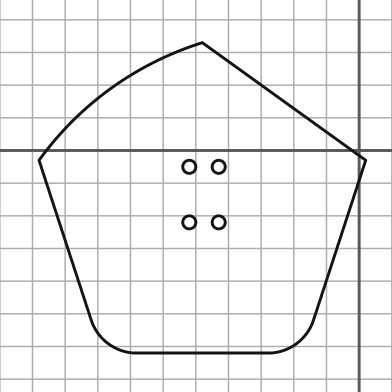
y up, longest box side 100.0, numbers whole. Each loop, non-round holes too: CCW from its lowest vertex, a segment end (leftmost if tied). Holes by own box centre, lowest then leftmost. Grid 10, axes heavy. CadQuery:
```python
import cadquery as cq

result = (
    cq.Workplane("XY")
    .moveTo(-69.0, -62.0)
    .lineTo(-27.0, -62.0)
    .threePointArc((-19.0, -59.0), (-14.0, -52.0))
    .lineTo(2.0, -3.0)
    .lineTo(-48.0, 33.0)
    .threePointArc((-76.0, 19.0), (-98.0, -3.0))
    .lineTo(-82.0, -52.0)
    .threePointArc((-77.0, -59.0), (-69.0, -62.0))
    .close()
    .moveTo(-52.0, -22.0)
    .circle(2.0)
    .moveTo(-43.0, -22.0)
    .circle(2.0)
    .moveTo(-52.0, -5.0)
    .circle(2.0)
    .moveTo(-43.0, -5.0)
    .circle(2.0)
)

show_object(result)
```